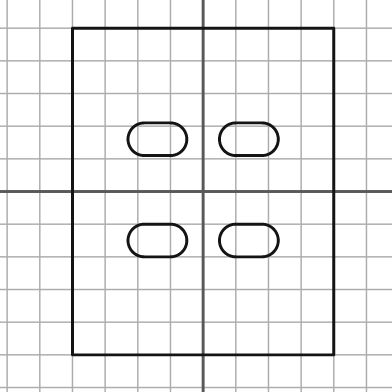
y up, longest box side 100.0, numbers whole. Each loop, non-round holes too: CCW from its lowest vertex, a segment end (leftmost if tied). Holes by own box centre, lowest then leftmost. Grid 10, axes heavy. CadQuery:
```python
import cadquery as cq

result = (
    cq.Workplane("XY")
    .moveTo(-40.0, -50.0)
    .lineTo(40.0, -50.0)
    .lineTo(40.0, 50.0)
    .lineTo(-40.0, 50.0)
    .close()
    .moveTo(-18.0, -20.0)
    .lineTo(-10.0, -20.0)
    .threePointArc((-5.0, -15.0), (-10.0, -10.0))
    .lineTo(-18.0, -10.0)
    .threePointArc((-23.0, -15.0), (-18.0, -20.0))
    .close()
    .moveTo(10.0, -20.0)
    .lineTo(18.0, -20.0)
    .threePointArc((23.0, -15.0), (18.0, -10.0))
    .lineTo(10.0, -10.0)
    .threePointArc((5.0, -15.0), (10.0, -20.0))
    .close()
    .moveTo(-18.0, 11.0)
    .lineTo(-10.0, 11.0)
    .threePointArc((-5.0, 16.0), (-10.0, 21.0))
    .lineTo(-18.0, 21.0)
    .threePointArc((-23.0, 16.0), (-18.0, 11.0))
    .close()
    .moveTo(10.0, 11.0)
    .lineTo(18.0, 11.0)
    .threePointArc((23.0, 16.0), (18.0, 21.0))
    .lineTo(10.0, 21.0)
    .threePointArc((5.0, 16.0), (10.0, 11.0))
    .close()
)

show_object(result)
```